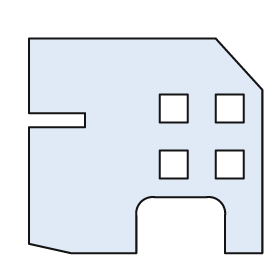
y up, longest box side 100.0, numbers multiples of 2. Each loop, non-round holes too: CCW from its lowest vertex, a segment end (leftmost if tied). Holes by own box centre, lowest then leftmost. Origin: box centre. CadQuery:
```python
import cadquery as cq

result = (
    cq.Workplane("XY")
    .moveTo(-32.0, -46.0)
    .lineTo(-4.0, -46.0)
    .lineTo(-4.0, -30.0)
    .threePointArc((-2.0, -24.0), (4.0, -22.0))
    .lineTo(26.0, -22.0)
    .threePointArc((32.0, -24.0), (34.0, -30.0))
    .lineTo(34.0, -46.0)
    .lineTo(50.0, -46.0)
    .lineTo(50.0, 24.0)
    .lineTo(30.0, 46.0)
    .lineTo(-50.0, 46.0)
    .lineTo(-50.0, 14.0)
    .lineTo(-26.0, 14.0)
    .lineTo(-26.0, 8.0)
    .lineTo(-50.0, 8.0)
    .lineTo(-50.0, -42.0)
    .close()
    .moveTo(6.0, -14.0)
    .lineTo(18.0, -14.0)
    .lineTo(18.0, -2.0)
    .lineTo(6.0, -2.0)
    .close()
    .moveTo(30.0, -14.0)
    .lineTo(42.0, -14.0)
    .lineTo(42.0, -2.0)
    .lineTo(30.0, -2.0)
    .close()
    .moveTo(6.0, 10.0)
    .lineTo(18.0, 10.0)
    .lineTo(18.0, 22.0)
    .lineTo(6.0, 22.0)
    .close()
    .moveTo(30.0, 10.0)
    .lineTo(42.0, 10.0)
    .lineTo(42.0, 22.0)
    .lineTo(30.0, 22.0)
    .close()
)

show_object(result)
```